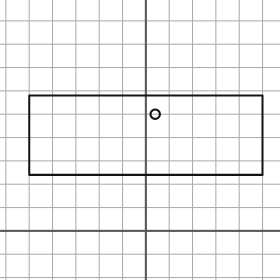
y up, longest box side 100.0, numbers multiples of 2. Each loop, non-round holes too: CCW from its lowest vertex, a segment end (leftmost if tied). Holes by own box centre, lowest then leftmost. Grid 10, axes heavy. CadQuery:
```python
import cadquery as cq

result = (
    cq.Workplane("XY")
    .moveTo(-50.0, 24.0)
    .lineTo(50.0, 24.0)
    .lineTo(50.0, 58.0)
    .lineTo(-50.0, 58.0)
    .close()
    .moveTo(4.0, 50.0)
    .circle(2.0)
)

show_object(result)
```